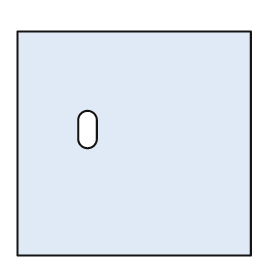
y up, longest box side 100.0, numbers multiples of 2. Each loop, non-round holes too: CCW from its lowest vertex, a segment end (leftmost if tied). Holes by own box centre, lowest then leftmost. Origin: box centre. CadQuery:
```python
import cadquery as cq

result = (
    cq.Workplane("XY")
    .moveTo(-50.0, -48.0)
    .lineTo(50.0, -48.0)
    .lineTo(50.0, 48.0)
    .lineTo(-50.0, 48.0)
    .close()
    .moveTo(-24.0, 2.0)
    .threePointArc((-20.0, -2.0), (-16.0, 2.0))
    .lineTo(-16.0, 10.0)
    .threePointArc((-20.0, 14.0), (-24.0, 10.0))
    .close()
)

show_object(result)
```